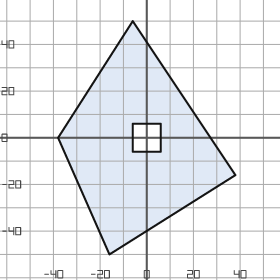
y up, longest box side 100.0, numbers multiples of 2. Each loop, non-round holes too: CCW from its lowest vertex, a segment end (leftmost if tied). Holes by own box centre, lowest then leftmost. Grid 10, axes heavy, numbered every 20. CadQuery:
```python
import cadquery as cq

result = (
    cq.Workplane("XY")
    .moveTo(-16.0, -50.0)
    .lineTo(38.0, -16.0)
    .lineTo(-6.0, 50.0)
    .lineTo(-38.0, 0.0)
    .close()
    .moveTo(-6.0, -6.0)
    .lineTo(6.0, -6.0)
    .lineTo(6.0, 6.0)
    .lineTo(-6.0, 6.0)
    .close()
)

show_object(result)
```